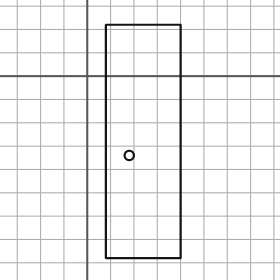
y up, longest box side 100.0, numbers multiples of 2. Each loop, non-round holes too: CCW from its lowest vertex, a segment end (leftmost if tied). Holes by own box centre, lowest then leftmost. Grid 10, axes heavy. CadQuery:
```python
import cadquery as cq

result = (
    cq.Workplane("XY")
    .moveTo(8.0, -78.0)
    .lineTo(40.0, -78.0)
    .lineTo(40.0, 22.0)
    .lineTo(8.0, 22.0)
    .close()
    .moveTo(18.0, -34.0)
    .circle(2.0)
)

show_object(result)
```